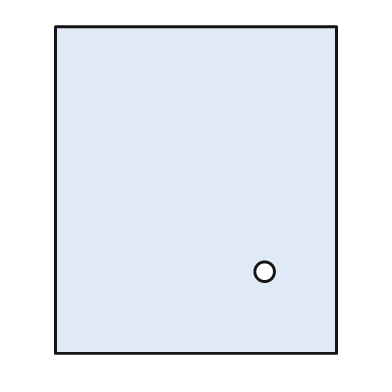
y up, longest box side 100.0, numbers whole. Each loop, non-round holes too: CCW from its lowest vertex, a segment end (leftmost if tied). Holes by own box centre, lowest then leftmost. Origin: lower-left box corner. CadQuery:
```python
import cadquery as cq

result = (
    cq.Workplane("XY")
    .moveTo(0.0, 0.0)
    .lineTo(86.0, 0.0)
    .lineTo(86.0, 100.0)
    .lineTo(0.0, 100.0)
    .close()
    .moveTo(64.0, 25.0)
    .circle(3.0)
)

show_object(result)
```